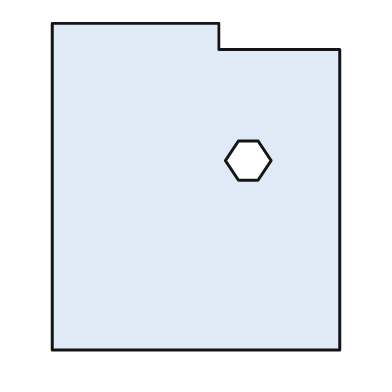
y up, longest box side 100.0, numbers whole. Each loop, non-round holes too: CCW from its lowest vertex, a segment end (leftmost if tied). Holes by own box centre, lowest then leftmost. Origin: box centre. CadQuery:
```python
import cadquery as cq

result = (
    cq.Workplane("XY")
    .moveTo(-44.0, -50.0)
    .lineTo(44.0, -50.0)
    .lineTo(44.0, 42.0)
    .lineTo(7.0, 42.0)
    .lineTo(7.0, 50.0)
    .lineTo(-44.0, 50.0)
    .close()
    .moveTo(13.0, 2.0)
    .lineTo(19.0, 2.0)
    .lineTo(23.0, 8.0)
    .lineTo(19.0, 14.0)
    .lineTo(13.0, 14.0)
    .lineTo(9.0, 8.0)
    .close()
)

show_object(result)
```